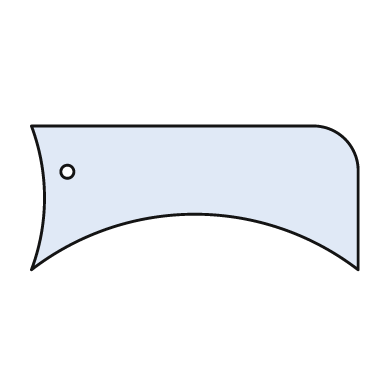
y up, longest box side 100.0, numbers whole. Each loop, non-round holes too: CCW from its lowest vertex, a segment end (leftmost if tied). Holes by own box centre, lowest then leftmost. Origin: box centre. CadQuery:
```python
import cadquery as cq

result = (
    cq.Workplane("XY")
    .moveTo(-50.0, -22.0)
    .threePointArc((0.0, -5.0), (50.0, -22.0))
    .lineTo(50.0, 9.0)
    .threePointArc((46.0, 18.0), (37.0, 22.0))
    .lineTo(-50.0, 22.0)
    .threePointArc((-46.0, 0.0), (-50.0, -22.0))
    .close()
    .moveTo(-39.0, 8.0)
    .circle(2.0)
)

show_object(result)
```